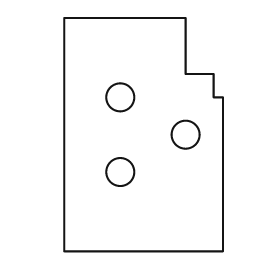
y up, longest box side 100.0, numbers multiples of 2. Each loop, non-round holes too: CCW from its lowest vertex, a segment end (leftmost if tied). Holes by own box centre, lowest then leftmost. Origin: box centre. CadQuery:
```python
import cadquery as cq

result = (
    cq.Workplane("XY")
    .moveTo(-34.0, -50.0)
    .lineTo(34.0, -50.0)
    .lineTo(34.0, 16.0)
    .lineTo(30.0, 16.0)
    .lineTo(30.0, 26.0)
    .lineTo(18.0, 26.0)
    .lineTo(18.0, 50.0)
    .lineTo(-34.0, 50.0)
    .close()
    .moveTo(-10.0, -16.0)
    .circle(6.0)
    .moveTo(18.0, 0.0)
    .circle(6.0)
    .moveTo(-10.0, 16.0)
    .circle(6.0)
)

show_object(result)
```